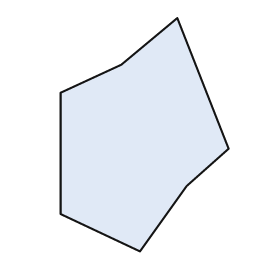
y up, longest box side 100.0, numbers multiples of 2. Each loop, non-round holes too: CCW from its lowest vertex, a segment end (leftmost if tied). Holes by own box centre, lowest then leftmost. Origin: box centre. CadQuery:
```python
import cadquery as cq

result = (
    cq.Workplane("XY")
    .moveTo(-2.0, -50.0)
    .lineTo(18.0, -22.0)
    .lineTo(36.0, -6.0)
    .lineTo(14.0, 50.0)
    .lineTo(-10.0, 30.0)
    .lineTo(-36.0, 18.0)
    .lineTo(-36.0, -34.0)
    .close()
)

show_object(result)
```